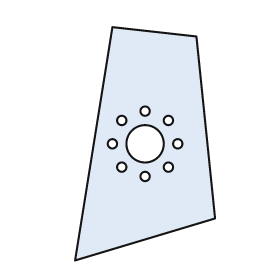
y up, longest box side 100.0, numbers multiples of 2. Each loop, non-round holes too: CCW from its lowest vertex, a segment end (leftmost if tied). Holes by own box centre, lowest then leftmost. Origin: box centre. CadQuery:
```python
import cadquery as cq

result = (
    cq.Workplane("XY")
    .moveTo(-30.0, -50.0)
    .lineTo(30.0, -32.0)
    .lineTo(22.0, 46.0)
    .lineTo(-14.0, 50.0)
    .close()
    .moveTo(0.0, -14.0)
    .circle(2.0)
    .moveTo(-10.0, -10.0)
    .circle(2.0)
    .moveTo(10.0, -10.0)
    .circle(2.0)
    .moveTo(-14.0, 0.0)
    .circle(2.0)
    .moveTo(0.0, 0.0)
    .circle(8.0)
    .moveTo(14.0, 0.0)
    .circle(2.0)
    .moveTo(-10.0, 10.0)
    .circle(2.0)
    .moveTo(10.0, 10.0)
    .circle(2.0)
    .moveTo(0.0, 14.0)
    .circle(2.0)
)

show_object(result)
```